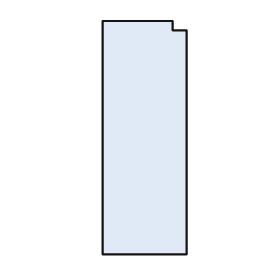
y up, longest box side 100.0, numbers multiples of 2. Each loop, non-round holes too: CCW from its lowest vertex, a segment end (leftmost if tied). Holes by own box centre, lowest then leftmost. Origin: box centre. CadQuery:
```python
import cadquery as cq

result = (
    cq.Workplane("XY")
    .moveTo(-18.0, -50.0)
    .lineTo(18.0, -50.0)
    .lineTo(18.0, 46.0)
    .lineTo(12.0, 46.0)
    .lineTo(12.0, 50.0)
    .lineTo(-18.0, 50.0)
    .close()
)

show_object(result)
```